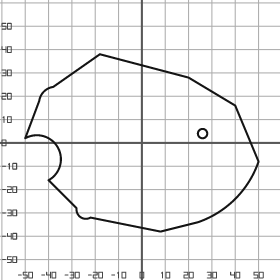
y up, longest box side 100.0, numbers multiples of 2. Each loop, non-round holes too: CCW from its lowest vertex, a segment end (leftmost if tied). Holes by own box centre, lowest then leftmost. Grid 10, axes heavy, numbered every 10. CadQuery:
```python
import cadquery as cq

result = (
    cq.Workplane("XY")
    .moveTo(8.0, -38.0)
    .lineTo(24.0, -34.0)
    .threePointArc((40.0, -24.0), (50.0, -8.0))
    .lineTo(40.0, 16.0)
    .lineTo(20.0, 28.0)
    .lineTo(-18.0, 38.0)
    .lineTo(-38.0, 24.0)
    .threePointArc((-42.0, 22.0), (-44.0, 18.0))
    .lineTo(-50.0, 2.0)
    .threePointArc((-36.0, -2.0), (-40.0, -16.0))
    .lineTo(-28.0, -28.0)
    .threePointArc((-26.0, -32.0), (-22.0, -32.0))
    .close()
    .moveTo(26.0, 4.0)
    .circle(2.0)
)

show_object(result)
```